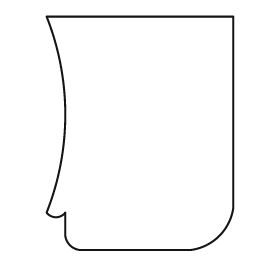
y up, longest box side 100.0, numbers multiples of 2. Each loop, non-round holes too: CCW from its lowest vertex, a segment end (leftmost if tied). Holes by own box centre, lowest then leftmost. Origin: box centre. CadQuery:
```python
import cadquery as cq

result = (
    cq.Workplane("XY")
    .moveTo(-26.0, -50.0)
    .lineTo(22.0, -50.0)
    .threePointArc((34.0, -44.0), (40.0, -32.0))
    .lineTo(40.0, 50.0)
    .lineTo(-40.0, 50.0)
    .threePointArc((-32.0, 8.0), (-40.0, -34.0))
    .threePointArc((-36.0, -36.0), (-32.0, -34.0))
    .lineTo(-32.0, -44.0)
    .threePointArc((-30.0, -48.0), (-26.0, -50.0))
    .close()
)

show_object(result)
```